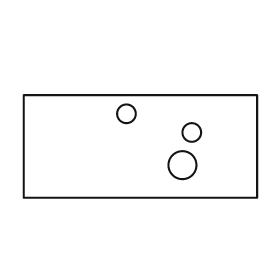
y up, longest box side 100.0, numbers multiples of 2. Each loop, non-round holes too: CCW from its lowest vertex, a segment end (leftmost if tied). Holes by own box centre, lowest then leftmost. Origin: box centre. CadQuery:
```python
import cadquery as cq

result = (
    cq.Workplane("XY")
    .moveTo(-50.0, -22.0)
    .lineTo(50.0, -22.0)
    .lineTo(50.0, 22.0)
    .lineTo(-50.0, 22.0)
    .close()
    .moveTo(18.0, -8.0)
    .circle(6.0)
    .moveTo(22.0, 6.0)
    .circle(4.0)
    .moveTo(-6.0, 14.0)
    .circle(4.0)
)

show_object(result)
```